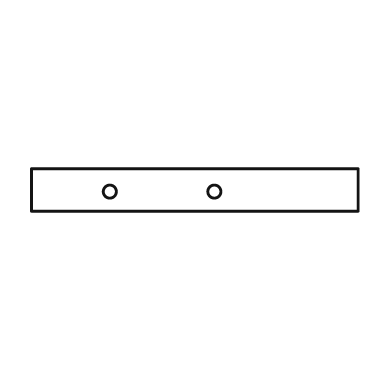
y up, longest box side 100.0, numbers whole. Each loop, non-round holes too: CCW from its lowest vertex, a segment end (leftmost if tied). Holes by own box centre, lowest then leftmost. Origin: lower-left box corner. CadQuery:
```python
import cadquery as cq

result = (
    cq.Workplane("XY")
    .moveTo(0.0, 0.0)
    .lineTo(100.0, 0.0)
    .lineTo(100.0, 13.0)
    .lineTo(0.0, 13.0)
    .close()
    .moveTo(24.0, 6.0)
    .circle(2.0)
    .moveTo(56.0, 6.0)
    .circle(2.0)
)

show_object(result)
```